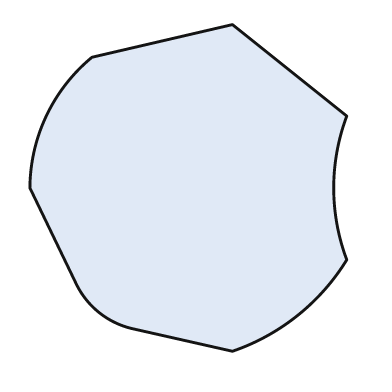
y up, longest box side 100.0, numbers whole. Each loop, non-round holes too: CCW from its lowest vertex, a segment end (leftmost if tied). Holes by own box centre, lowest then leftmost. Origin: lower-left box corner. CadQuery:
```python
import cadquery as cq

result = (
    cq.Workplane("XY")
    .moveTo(62.0, 0.0)
    .threePointArc((82.0, 11.0), (97.0, 28.0))
    .threePointArc((93.0, 50.0), (97.0, 72.0))
    .lineTo(62.0, 100.0)
    .lineTo(19.0, 90.0)
    .threePointArc((5.0, 72.0), (0.0, 50.0))
    .lineTo(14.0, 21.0)
    .threePointArc((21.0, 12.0), (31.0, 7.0))
    .close()
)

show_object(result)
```